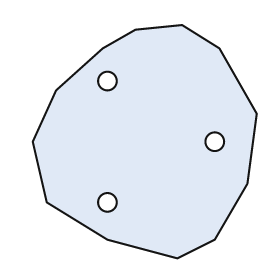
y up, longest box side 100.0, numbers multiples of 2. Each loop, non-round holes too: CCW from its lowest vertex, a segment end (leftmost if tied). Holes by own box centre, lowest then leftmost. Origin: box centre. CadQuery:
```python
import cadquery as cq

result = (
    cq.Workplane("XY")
    .moveTo(14.0, -50.0)
    .lineTo(30.0, -42.0)
    .lineTo(44.0, -18.0)
    .lineTo(48.0, 12.0)
    .lineTo(32.0, 40.0)
    .lineTo(16.0, 50.0)
    .lineTo(-4.0, 48.0)
    .lineTo(-18.0, 40.0)
    .lineTo(-38.0, 22.0)
    .lineTo(-48.0, 0.0)
    .lineTo(-42.0, -26.0)
    .lineTo(-16.0, -42.0)
    .close()
    .moveTo(-16.0, -26.0)
    .circle(4.0)
    .moveTo(30.0, 0.0)
    .circle(4.0)
    .moveTo(-16.0, 26.0)
    .circle(4.0)
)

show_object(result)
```